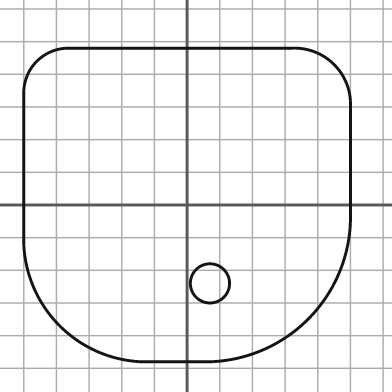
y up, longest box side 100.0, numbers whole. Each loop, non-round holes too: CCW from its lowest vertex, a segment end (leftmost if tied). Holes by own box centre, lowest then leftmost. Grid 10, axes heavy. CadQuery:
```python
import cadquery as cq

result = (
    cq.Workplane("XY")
    .moveTo(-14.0, -48.0)
    .lineTo(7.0, -48.0)
    .threePointArc((37.0, -35.0), (50.0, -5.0))
    .lineTo(50.0, 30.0)
    .threePointArc((45.0, 43.0), (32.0, 48.0))
    .lineTo(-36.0, 48.0)
    .threePointArc((-46.0, 44.0), (-50.0, 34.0))
    .lineTo(-50.0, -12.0)
    .threePointArc((-39.0, -37.0), (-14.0, -48.0))
    .close()
    .moveTo(7.0, -24.0)
    .circle(6.0)
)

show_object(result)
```